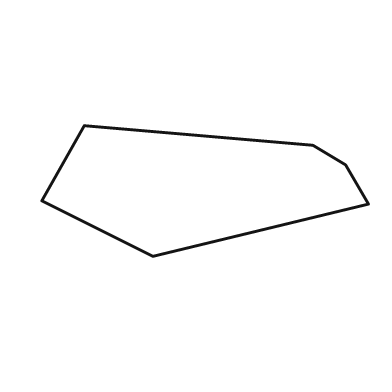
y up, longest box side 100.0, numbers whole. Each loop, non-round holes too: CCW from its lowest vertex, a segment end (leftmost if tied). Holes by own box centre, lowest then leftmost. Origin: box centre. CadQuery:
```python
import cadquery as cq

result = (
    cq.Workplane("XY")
    .moveTo(-16.0, -20.0)
    .lineTo(50.0, -4.0)
    .lineTo(43.0, 8.0)
    .lineTo(33.0, 14.0)
    .lineTo(-37.0, 20.0)
    .lineTo(-50.0, -3.0)
    .close()
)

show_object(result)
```